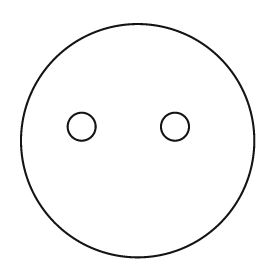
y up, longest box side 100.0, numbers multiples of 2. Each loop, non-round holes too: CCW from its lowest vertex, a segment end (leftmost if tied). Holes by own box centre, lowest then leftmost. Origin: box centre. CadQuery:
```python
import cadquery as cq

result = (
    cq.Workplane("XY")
    .moveTo(0.0, 0.0)
    .circle(50.0)
    .moveTo(-24.0, 6.0)
    .circle(6.0)
    .moveTo(16.0, 6.0)
    .circle(6.0)
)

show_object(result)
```